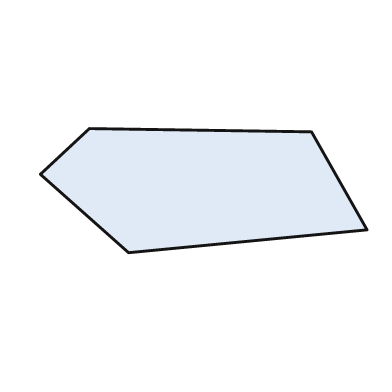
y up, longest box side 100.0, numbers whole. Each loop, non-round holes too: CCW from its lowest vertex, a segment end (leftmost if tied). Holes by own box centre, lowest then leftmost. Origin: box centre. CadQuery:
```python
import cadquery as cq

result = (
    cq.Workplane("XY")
    .moveTo(-23.0, -19.0)
    .lineTo(50.0, -12.0)
    .lineTo(33.0, 18.0)
    .lineTo(-35.0, 19.0)
    .lineTo(-50.0, 5.0)
    .close()
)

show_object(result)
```